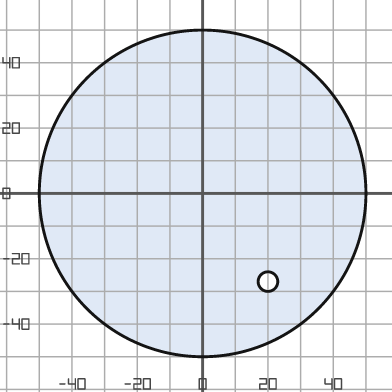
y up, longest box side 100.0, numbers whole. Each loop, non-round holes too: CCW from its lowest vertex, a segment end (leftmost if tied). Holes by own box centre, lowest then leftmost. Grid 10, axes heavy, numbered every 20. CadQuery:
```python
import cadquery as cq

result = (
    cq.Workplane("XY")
    .moveTo(0.0, 0.0)
    .circle(50.0)
    .moveTo(20.0, -27.0)
    .circle(3.0)
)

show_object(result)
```